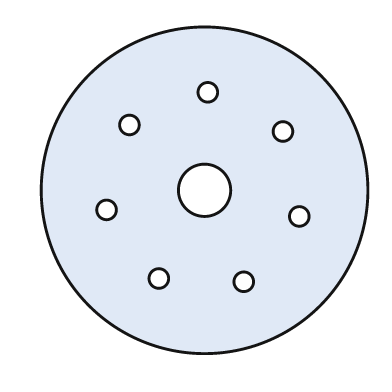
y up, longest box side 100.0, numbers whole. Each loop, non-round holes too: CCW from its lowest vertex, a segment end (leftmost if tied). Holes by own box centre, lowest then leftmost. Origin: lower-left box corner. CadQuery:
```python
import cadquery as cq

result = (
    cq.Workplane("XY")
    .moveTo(50.0, 50.0)
    .circle(50.0)
    .moveTo(62.0, 22.0)
    .circle(3.0)
    .moveTo(36.0, 23.0)
    .circle(3.0)
    .moveTo(79.0, 42.0)
    .circle(3.0)
    .moveTo(20.0, 44.0)
    .circle(3.0)
    .moveTo(50.0, 50.0)
    .circle(8.0)
    .moveTo(74.0, 68.0)
    .circle(3.0)
    .moveTo(27.0, 70.0)
    .circle(3.0)
    .moveTo(51.0, 80.0)
    .circle(3.0)
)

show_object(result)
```